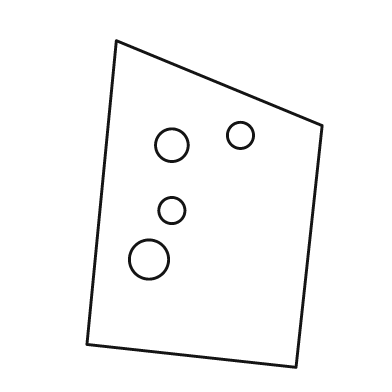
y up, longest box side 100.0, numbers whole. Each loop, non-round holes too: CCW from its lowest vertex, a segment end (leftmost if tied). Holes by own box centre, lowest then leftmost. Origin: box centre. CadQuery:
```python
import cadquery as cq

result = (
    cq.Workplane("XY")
    .moveTo(28.0, -50.0)
    .lineTo(36.0, 24.0)
    .lineTo(-27.0, 50.0)
    .lineTo(-36.0, -43.0)
    .close()
    .moveTo(-17.0, -17.0)
    .circle(6.0)
    .moveTo(-10.0, -2.0)
    .circle(4.0)
    .moveTo(-10.0, 18.0)
    .circle(5.0)
    .moveTo(11.0, 21.0)
    .circle(4.0)
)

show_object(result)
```